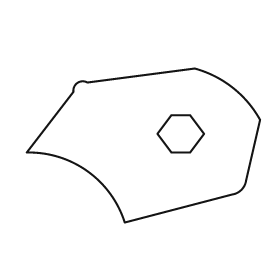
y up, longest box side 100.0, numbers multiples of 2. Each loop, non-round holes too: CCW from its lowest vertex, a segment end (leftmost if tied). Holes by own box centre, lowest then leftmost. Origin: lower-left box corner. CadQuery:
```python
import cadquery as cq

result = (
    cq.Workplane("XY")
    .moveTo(42.0, 0.0)
    .lineTo(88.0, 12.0)
    .threePointArc((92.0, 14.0), (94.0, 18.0))
    .lineTo(100.0, 44.0)
    .threePointArc((88.0, 58.0), (72.0, 66.0))
    .lineTo(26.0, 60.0)
    .threePointArc((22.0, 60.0), (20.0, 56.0))
    .lineTo(0.0, 30.0)
    .threePointArc((26.0, 22.0), (42.0, 0.0))
    .close()
    .moveTo(62.0, 30.0)
    .lineTo(70.0, 30.0)
    .lineTo(76.0, 38.0)
    .lineTo(70.0, 46.0)
    .lineTo(62.0, 46.0)
    .lineTo(56.0, 38.0)
    .close()
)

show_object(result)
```